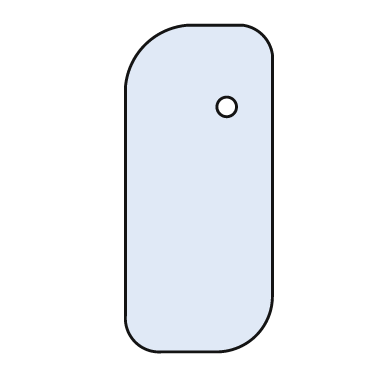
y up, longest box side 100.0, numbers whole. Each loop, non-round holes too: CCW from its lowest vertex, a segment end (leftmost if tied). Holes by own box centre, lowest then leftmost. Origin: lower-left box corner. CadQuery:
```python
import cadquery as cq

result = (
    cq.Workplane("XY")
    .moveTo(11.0, 0.0)
    .lineTo(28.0, 0.0)
    .threePointArc((40.0, 5.0), (45.0, 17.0))
    .lineTo(45.0, 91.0)
    .threePointArc((42.0, 97.0), (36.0, 100.0))
    .lineTo(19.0, 100.0)
    .threePointArc((6.0, 94.0), (0.0, 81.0))
    .lineTo(0.0, 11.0)
    .threePointArc((3.0, 3.0), (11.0, 0.0))
    .close()
    .moveTo(31.0, 75.0)
    .circle(3.0)
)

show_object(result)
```